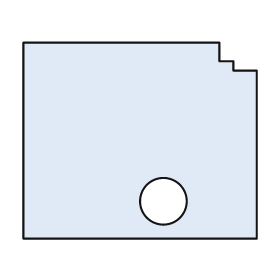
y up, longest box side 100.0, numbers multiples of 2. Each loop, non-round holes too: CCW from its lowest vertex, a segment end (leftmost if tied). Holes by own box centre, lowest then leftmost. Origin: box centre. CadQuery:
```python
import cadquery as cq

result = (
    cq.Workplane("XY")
    .moveTo(-50.0, -42.0)
    .lineTo(50.0, -42.0)
    .lineTo(50.0, 30.0)
    .lineTo(40.0, 30.0)
    .lineTo(40.0, 34.0)
    .lineTo(34.0, 34.0)
    .lineTo(34.0, 42.0)
    .lineTo(-50.0, 42.0)
    .close()
    .moveTo(10.0, -26.0)
    .circle(10.0)
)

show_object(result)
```